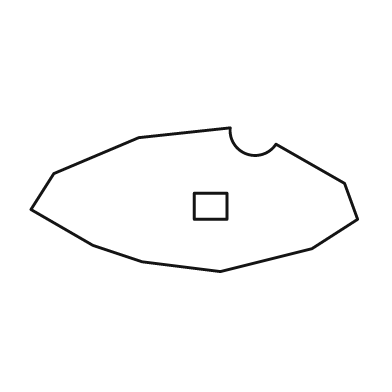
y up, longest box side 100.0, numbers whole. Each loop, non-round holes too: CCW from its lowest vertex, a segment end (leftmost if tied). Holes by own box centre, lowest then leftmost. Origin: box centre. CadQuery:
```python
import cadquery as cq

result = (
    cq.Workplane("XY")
    .moveTo(8.0, -22.0)
    .lineTo(36.0, -15.0)
    .lineTo(50.0, -6.0)
    .lineTo(46.0, 5.0)
    .lineTo(25.0, 17.0)
    .threePointArc((16.0, 14.0), (11.0, 22.0))
    .lineTo(-17.0, 19.0)
    .lineTo(-43.0, 8.0)
    .lineTo(-50.0, -3.0)
    .lineTo(-31.0, -14.0)
    .lineTo(-16.0, -19.0)
    .close()
    .moveTo(0.0, -6.0)
    .lineTo(10.0, -6.0)
    .lineTo(10.0, 2.0)
    .lineTo(0.0, 2.0)
    .close()
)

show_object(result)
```